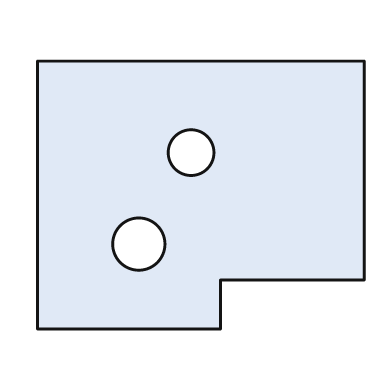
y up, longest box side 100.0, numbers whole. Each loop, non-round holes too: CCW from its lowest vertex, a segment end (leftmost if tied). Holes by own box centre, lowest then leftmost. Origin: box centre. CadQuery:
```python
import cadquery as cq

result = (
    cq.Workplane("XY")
    .moveTo(-50.0, -41.0)
    .lineTo(6.0, -41.0)
    .lineTo(6.0, -26.0)
    .lineTo(50.0, -26.0)
    .lineTo(50.0, 41.0)
    .lineTo(-50.0, 41.0)
    .close()
    .moveTo(-19.0, -15.0)
    .circle(8.0)
    .moveTo(-3.0, 13.0)
    .circle(7.0)
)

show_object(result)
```